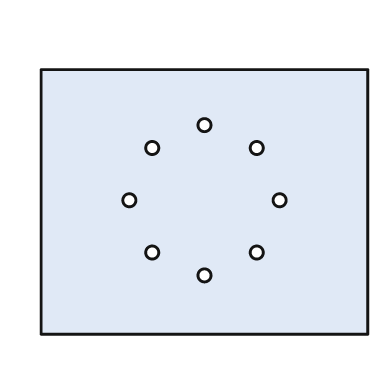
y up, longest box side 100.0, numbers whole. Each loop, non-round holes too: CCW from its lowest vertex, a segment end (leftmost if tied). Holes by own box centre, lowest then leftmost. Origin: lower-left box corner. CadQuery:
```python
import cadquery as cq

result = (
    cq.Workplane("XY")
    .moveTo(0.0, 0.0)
    .lineTo(100.0, 0.0)
    .lineTo(100.0, 81.0)
    .lineTo(0.0, 81.0)
    .close()
    .moveTo(50.0, 18.0)
    .circle(2.0)
    .moveTo(34.0, 25.0)
    .circle(2.0)
    .moveTo(66.0, 25.0)
    .circle(2.0)
    .moveTo(27.0, 41.0)
    .circle(2.0)
    .moveTo(73.0, 41.0)
    .circle(2.0)
    .moveTo(34.0, 57.0)
    .circle(2.0)
    .moveTo(66.0, 57.0)
    .circle(2.0)
    .moveTo(50.0, 64.0)
    .circle(2.0)
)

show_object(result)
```